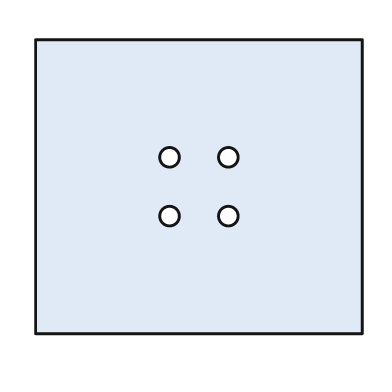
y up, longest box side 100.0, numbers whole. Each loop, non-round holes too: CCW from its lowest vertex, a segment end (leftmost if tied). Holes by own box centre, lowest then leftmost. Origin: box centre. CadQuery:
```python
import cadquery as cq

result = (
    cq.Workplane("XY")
    .moveTo(-50.0, -45.0)
    .lineTo(50.0, -45.0)
    .lineTo(50.0, 45.0)
    .lineTo(-50.0, 45.0)
    .close()
    .moveTo(-9.0, -9.0)
    .circle(3.0)
    .moveTo(9.0, -9.0)
    .circle(3.0)
    .moveTo(-9.0, 9.0)
    .circle(3.0)
    .moveTo(9.0, 9.0)
    .circle(3.0)
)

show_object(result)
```